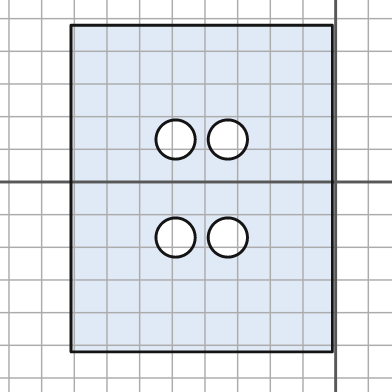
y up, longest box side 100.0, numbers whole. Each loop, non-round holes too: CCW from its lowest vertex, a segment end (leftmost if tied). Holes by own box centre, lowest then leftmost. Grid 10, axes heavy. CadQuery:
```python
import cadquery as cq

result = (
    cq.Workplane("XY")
    .moveTo(-81.0, -52.0)
    .lineTo(-1.0, -52.0)
    .lineTo(-1.0, 48.0)
    .lineTo(-81.0, 48.0)
    .close()
    .moveTo(-49.0, -17.0)
    .circle(6.0)
    .moveTo(-33.0, -17.0)
    .circle(6.0)
    .moveTo(-49.0, 13.0)
    .circle(6.0)
    .moveTo(-33.0, 13.0)
    .circle(6.0)
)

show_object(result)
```